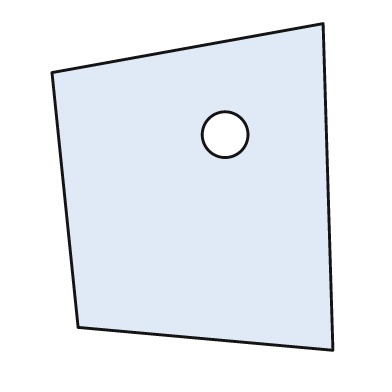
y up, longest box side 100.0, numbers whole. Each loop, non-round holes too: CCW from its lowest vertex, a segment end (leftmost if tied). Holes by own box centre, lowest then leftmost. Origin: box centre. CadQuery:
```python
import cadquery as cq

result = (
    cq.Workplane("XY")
    .moveTo(43.0, -50.0)
    .lineTo(40.0, 50.0)
    .lineTo(-43.0, 35.0)
    .lineTo(-35.0, -43.0)
    .close()
    .moveTo(10.0, 16.0)
    .circle(7.0)
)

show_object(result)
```